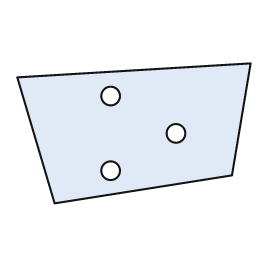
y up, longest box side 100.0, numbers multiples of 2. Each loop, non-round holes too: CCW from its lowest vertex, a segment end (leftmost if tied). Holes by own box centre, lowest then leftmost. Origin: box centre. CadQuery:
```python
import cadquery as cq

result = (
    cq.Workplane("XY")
    .moveTo(-34.0, -30.0)
    .lineTo(42.0, -18.0)
    .lineTo(50.0, 30.0)
    .lineTo(-50.0, 24.0)
    .close()
    .moveTo(-10.0, -16.0)
    .circle(4.0)
    .moveTo(18.0, 0.0)
    .circle(4.0)
    .moveTo(-10.0, 16.0)
    .circle(4.0)
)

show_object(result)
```